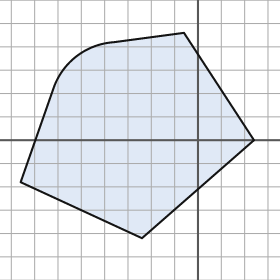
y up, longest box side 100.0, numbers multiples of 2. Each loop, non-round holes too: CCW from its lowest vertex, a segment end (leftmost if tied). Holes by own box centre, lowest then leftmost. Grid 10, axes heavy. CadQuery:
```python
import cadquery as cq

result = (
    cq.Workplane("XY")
    .moveTo(-24.0, -42.0)
    .lineTo(24.0, 0.0)
    .lineTo(-6.0, 46.0)
    .lineTo(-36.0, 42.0)
    .threePointArc((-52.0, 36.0), (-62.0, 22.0))
    .lineTo(-76.0, -18.0)
    .close()
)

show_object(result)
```